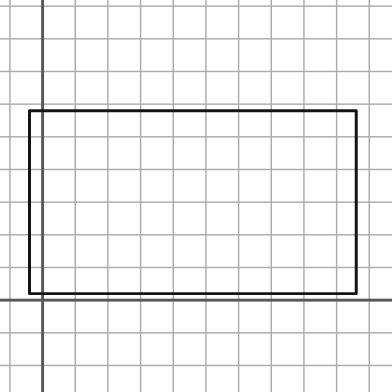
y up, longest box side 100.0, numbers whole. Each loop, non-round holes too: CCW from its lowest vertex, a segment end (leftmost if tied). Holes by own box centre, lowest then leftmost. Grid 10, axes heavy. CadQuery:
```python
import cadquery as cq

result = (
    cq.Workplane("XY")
    .moveTo(-4.0, 2.0)
    .lineTo(96.0, 2.0)
    .lineTo(96.0, 58.0)
    .lineTo(-4.0, 58.0)
    .close()
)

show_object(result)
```